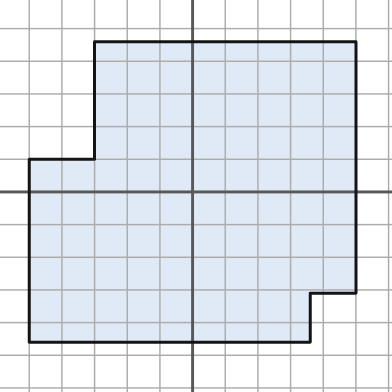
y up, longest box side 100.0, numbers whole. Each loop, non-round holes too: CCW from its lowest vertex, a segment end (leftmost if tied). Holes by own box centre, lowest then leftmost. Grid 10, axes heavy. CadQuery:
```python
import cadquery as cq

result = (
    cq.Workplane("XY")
    .moveTo(-50.0, -46.0)
    .lineTo(36.0, -46.0)
    .lineTo(36.0, -31.0)
    .lineTo(50.0, -31.0)
    .lineTo(50.0, 46.0)
    .lineTo(-30.0, 46.0)
    .lineTo(-30.0, 10.0)
    .lineTo(-50.0, 10.0)
    .close()
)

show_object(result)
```